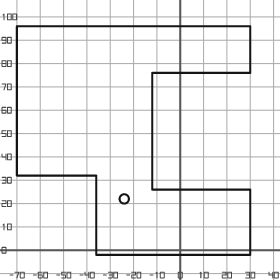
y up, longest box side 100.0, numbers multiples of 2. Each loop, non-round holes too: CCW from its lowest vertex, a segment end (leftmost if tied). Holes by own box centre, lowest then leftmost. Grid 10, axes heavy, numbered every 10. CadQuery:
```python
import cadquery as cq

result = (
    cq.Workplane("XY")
    .moveTo(-36.0, -2.0)
    .lineTo(30.0, -2.0)
    .lineTo(30.0, 26.0)
    .lineTo(-12.0, 26.0)
    .lineTo(-12.0, 76.0)
    .lineTo(30.0, 76.0)
    .lineTo(30.0, 96.0)
    .lineTo(-70.0, 96.0)
    .lineTo(-70.0, 32.0)
    .lineTo(-36.0, 32.0)
    .close()
    .moveTo(-24.0, 22.0)
    .circle(2.0)
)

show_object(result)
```